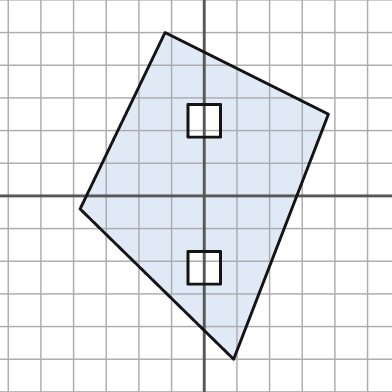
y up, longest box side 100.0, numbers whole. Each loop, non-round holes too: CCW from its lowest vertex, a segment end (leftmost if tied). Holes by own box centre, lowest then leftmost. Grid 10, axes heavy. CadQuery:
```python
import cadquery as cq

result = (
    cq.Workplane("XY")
    .moveTo(9.0, -50.0)
    .lineTo(38.0, 25.0)
    .lineTo(-12.0, 50.0)
    .lineTo(-38.0, -4.0)
    .close()
    .moveTo(-5.0, -27.0)
    .lineTo(5.0, -27.0)
    .lineTo(5.0, -17.0)
    .lineTo(-5.0, -17.0)
    .close()
    .moveTo(-5.0, 18.0)
    .lineTo(5.0, 18.0)
    .lineTo(5.0, 28.0)
    .lineTo(-5.0, 28.0)
    .close()
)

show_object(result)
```